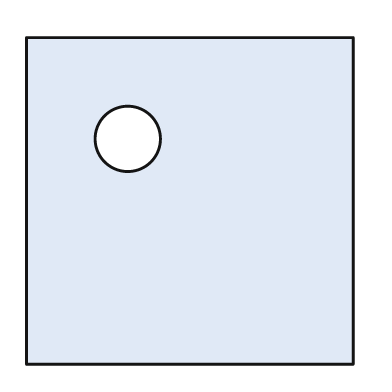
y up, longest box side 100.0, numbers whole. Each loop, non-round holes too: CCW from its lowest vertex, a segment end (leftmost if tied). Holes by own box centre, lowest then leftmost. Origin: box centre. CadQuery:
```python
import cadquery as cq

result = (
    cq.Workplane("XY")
    .moveTo(-50.0, -50.0)
    .lineTo(50.0, -50.0)
    .lineTo(50.0, 50.0)
    .lineTo(-50.0, 50.0)
    .close()
    .moveTo(-19.0, 19.0)
    .circle(10.0)
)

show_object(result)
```